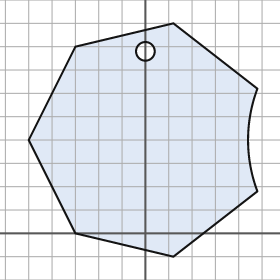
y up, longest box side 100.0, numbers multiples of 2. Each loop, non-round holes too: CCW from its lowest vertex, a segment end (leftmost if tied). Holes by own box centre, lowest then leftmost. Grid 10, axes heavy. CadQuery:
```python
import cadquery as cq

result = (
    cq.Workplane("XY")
    .moveTo(12.0, -10.0)
    .lineTo(48.0, 18.0)
    .threePointArc((44.0, 40.0), (48.0, 62.0))
    .lineTo(12.0, 90.0)
    .lineTo(-30.0, 80.0)
    .lineTo(-50.0, 40.0)
    .lineTo(-30.0, 0.0)
    .close()
    .moveTo(0.0, 78.0)
    .circle(4.0)
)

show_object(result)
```